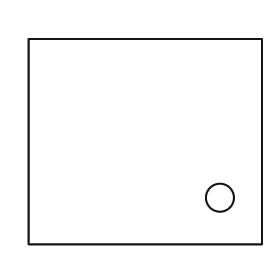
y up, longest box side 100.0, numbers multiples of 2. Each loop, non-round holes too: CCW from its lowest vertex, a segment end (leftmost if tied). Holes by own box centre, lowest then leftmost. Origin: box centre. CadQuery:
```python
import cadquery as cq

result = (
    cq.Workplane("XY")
    .moveTo(-50.0, -44.0)
    .lineTo(50.0, -44.0)
    .lineTo(50.0, 44.0)
    .lineTo(-50.0, 44.0)
    .close()
    .moveTo(32.0, -24.0)
    .circle(6.0)
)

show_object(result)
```